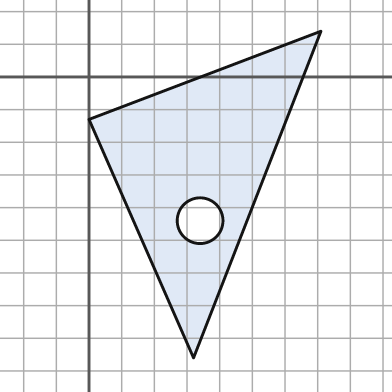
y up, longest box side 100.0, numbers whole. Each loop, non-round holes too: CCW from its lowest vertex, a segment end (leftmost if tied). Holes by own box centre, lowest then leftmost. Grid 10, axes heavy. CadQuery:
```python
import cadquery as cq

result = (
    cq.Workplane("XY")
    .moveTo(32.0, -86.0)
    .lineTo(71.0, 14.0)
    .lineTo(0.0, -13.0)
    .close()
    .moveTo(34.0, -44.0)
    .circle(7.0)
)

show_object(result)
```